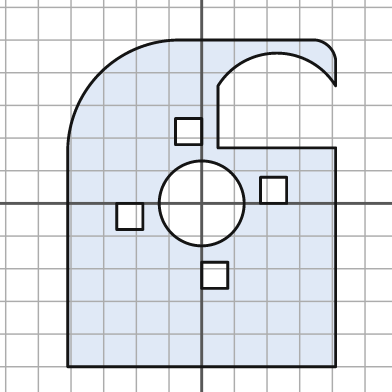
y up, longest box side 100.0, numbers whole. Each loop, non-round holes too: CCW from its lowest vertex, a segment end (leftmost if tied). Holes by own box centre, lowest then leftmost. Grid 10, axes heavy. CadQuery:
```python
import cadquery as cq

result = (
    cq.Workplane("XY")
    .moveTo(-41.0, -50.0)
    .lineTo(41.0, -50.0)
    .lineTo(41.0, 17.0)
    .lineTo(5.0, 17.0)
    .lineTo(5.0, 36.0)
    .threePointArc((23.0, 46.0), (41.0, 36.0))
    .lineTo(41.0, 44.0)
    .threePointArc((39.0, 48.0), (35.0, 50.0))
    .lineTo(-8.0, 50.0)
    .threePointArc((-31.0, 40.0), (-41.0, 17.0))
    .close()
    .moveTo(0.0, -26.0)
    .lineTo(8.0, -26.0)
    .lineTo(8.0, -18.0)
    .lineTo(0.0, -18.0)
    .close()
    .moveTo(-26.0, -8.0)
    .lineTo(-18.0, -8.0)
    .lineTo(-18.0, 0.0)
    .lineTo(-26.0, 0.0)
    .close()
    .moveTo(0.0, 0.0)
    .circle(13.0)
    .moveTo(18.0, 0.0)
    .lineTo(26.0, 0.0)
    .lineTo(26.0, 8.0)
    .lineTo(18.0, 8.0)
    .close()
    .moveTo(-8.0, 18.0)
    .lineTo(0.0, 18.0)
    .lineTo(0.0, 26.0)
    .lineTo(-8.0, 26.0)
    .close()
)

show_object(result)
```